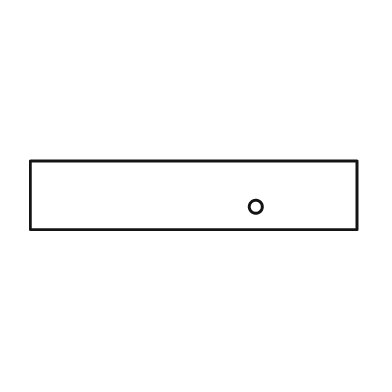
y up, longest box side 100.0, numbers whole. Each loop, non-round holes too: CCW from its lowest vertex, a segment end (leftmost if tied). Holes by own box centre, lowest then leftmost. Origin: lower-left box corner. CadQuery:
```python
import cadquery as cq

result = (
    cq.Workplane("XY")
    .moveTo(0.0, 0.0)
    .lineTo(100.0, 0.0)
    .lineTo(100.0, 21.0)
    .lineTo(0.0, 21.0)
    .close()
    .moveTo(69.0, 7.0)
    .circle(2.0)
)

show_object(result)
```